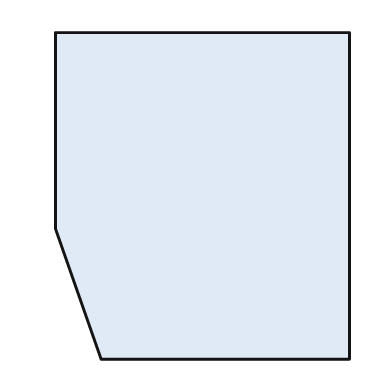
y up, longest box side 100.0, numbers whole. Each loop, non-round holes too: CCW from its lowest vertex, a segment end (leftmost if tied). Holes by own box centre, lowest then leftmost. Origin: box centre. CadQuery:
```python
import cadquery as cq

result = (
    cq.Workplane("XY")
    .moveTo(-31.0, -50.0)
    .lineTo(45.0, -50.0)
    .lineTo(45.0, 50.0)
    .lineTo(-45.0, 50.0)
    .lineTo(-45.0, -10.0)
    .close()
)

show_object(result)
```